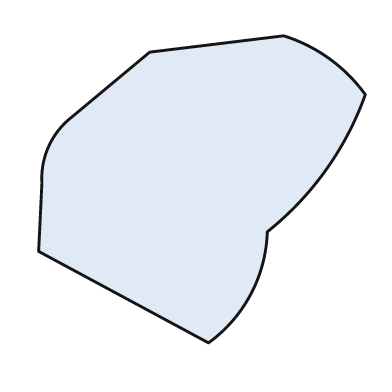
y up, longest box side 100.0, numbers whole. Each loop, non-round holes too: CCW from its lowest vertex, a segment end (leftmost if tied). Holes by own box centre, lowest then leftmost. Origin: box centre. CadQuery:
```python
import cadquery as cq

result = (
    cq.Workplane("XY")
    .moveTo(2.0, -47.0)
    .threePointArc((15.0, -32.0), (20.0, -13.0))
    .threePointArc((38.0, 6.0), (50.0, 29.0))
    .threePointArc((39.0, 40.0), (25.0, 47.0))
    .lineTo(-16.0, 42.0)
    .lineTo(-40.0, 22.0)
    .threePointArc((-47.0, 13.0), (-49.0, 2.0))
    .lineTo(-50.0, -19.0)
    .close()
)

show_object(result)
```